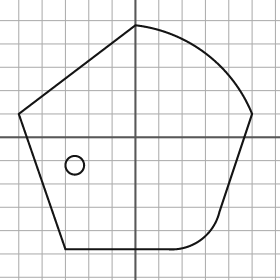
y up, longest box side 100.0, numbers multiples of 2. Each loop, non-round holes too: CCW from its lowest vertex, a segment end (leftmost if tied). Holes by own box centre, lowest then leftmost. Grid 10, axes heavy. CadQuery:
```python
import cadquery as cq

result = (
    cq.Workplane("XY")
    .moveTo(-30.0, -48.0)
    .lineTo(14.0, -48.0)
    .threePointArc((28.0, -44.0), (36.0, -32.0))
    .lineTo(50.0, 10.0)
    .threePointArc((30.0, 36.0), (0.0, 48.0))
    .lineTo(-50.0, 10.0)
    .close()
    .moveTo(-26.0, -12.0)
    .circle(4.0)
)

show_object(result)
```